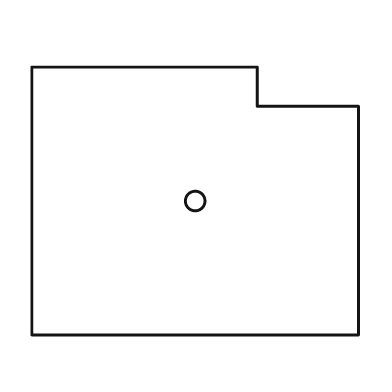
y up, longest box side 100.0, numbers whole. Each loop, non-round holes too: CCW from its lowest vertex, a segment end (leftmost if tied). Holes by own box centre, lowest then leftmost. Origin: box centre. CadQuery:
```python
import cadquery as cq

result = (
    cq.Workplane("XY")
    .moveTo(-50.0, -41.0)
    .lineTo(50.0, -41.0)
    .lineTo(50.0, 29.0)
    .lineTo(19.0, 29.0)
    .lineTo(19.0, 41.0)
    .lineTo(-50.0, 41.0)
    .close()
    .moveTo(0.0, 0.0)
    .circle(3.0)
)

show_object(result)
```